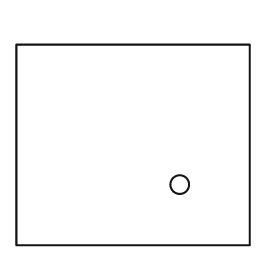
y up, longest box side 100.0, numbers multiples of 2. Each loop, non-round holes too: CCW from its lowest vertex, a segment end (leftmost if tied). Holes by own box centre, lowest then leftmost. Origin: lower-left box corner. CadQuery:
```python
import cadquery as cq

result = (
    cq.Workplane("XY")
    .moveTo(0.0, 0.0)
    .lineTo(100.0, 0.0)
    .lineTo(100.0, 86.0)
    .lineTo(0.0, 86.0)
    .close()
    .moveTo(70.0, 26.0)
    .circle(4.0)
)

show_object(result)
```